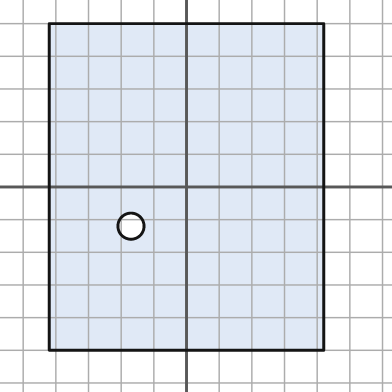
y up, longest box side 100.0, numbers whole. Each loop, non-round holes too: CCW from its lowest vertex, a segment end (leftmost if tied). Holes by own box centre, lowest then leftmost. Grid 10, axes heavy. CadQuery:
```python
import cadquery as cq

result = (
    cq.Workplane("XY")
    .moveTo(-42.0, -50.0)
    .lineTo(42.0, -50.0)
    .lineTo(42.0, 50.0)
    .lineTo(-42.0, 50.0)
    .close()
    .moveTo(-17.0, -12.0)
    .circle(4.0)
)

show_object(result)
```